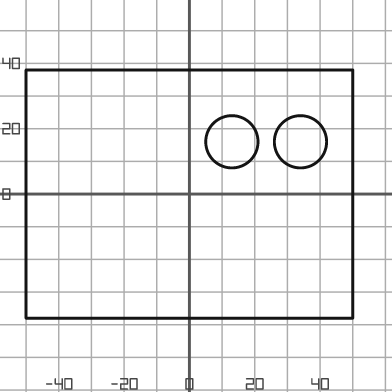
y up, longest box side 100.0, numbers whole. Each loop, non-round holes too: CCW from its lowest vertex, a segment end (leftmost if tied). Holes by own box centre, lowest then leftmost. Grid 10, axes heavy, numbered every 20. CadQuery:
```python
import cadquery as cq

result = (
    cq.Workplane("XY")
    .moveTo(-50.0, -38.0)
    .lineTo(50.0, -38.0)
    .lineTo(50.0, 38.0)
    .lineTo(-50.0, 38.0)
    .close()
    .moveTo(13.0, 16.0)
    .circle(8.0)
    .moveTo(34.0, 16.0)
    .circle(8.0)
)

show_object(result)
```